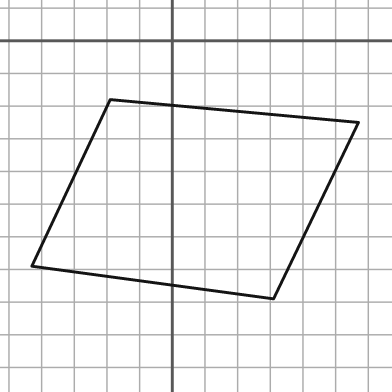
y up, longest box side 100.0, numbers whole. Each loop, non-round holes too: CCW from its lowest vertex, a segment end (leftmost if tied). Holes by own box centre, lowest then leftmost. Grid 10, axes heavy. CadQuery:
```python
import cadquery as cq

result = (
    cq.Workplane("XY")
    .moveTo(31.0, -79.0)
    .lineTo(57.0, -25.0)
    .lineTo(-19.0, -18.0)
    .lineTo(-43.0, -69.0)
    .close()
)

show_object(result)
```